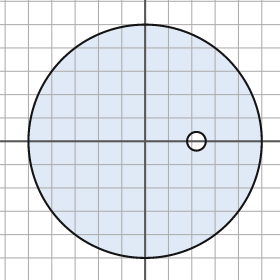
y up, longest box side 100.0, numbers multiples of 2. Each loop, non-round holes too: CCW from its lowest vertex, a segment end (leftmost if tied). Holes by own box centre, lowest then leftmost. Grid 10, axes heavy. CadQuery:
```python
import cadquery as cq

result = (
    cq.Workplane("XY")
    .moveTo(0.0, 0.0)
    .circle(50.0)
    .moveTo(22.0, 0.0)
    .circle(4.0)
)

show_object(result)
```